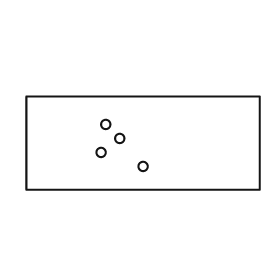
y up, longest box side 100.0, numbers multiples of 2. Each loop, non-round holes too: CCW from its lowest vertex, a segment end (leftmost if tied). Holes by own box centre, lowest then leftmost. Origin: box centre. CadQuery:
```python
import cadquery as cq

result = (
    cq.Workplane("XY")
    .moveTo(-50.0, -20.0)
    .lineTo(50.0, -20.0)
    .lineTo(50.0, 20.0)
    .lineTo(-50.0, 20.0)
    .close()
    .moveTo(0.0, -10.0)
    .circle(2.0)
    .moveTo(-18.0, -4.0)
    .circle(2.0)
    .moveTo(-10.0, 2.0)
    .circle(2.0)
    .moveTo(-16.0, 8.0)
    .circle(2.0)
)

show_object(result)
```